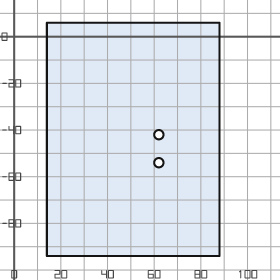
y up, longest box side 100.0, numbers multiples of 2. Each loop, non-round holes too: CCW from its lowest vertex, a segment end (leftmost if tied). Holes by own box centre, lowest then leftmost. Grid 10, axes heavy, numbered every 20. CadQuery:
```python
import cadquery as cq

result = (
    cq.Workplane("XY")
    .moveTo(14.0, -94.0)
    .lineTo(88.0, -94.0)
    .lineTo(88.0, 6.0)
    .lineTo(14.0, 6.0)
    .close()
    .moveTo(62.0, -54.0)
    .circle(2.0)
    .moveTo(62.0, -42.0)
    .circle(2.0)
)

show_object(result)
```